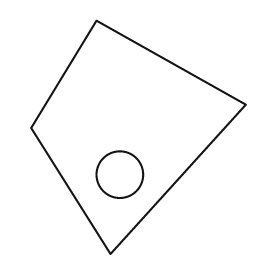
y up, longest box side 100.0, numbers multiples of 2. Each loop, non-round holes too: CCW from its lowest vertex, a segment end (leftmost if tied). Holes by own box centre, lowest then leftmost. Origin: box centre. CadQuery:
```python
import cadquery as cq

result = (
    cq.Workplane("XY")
    .moveTo(-12.0, -50.0)
    .lineTo(46.0, 14.0)
    .lineTo(-18.0, 50.0)
    .lineTo(-46.0, 4.0)
    .close()
    .moveTo(-8.0, -16.0)
    .circle(10.0)
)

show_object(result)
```